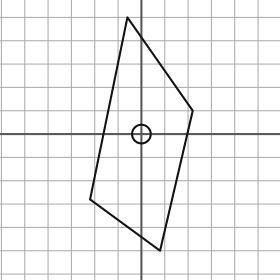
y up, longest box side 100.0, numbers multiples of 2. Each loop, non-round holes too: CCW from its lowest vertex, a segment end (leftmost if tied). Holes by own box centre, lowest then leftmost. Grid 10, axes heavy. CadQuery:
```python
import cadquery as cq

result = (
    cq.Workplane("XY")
    .moveTo(8.0, -50.0)
    .lineTo(22.0, 10.0)
    .lineTo(-6.0, 50.0)
    .lineTo(-22.0, -28.0)
    .close()
    .moveTo(0.0, 0.0)
    .circle(4.0)
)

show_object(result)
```